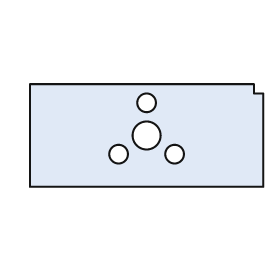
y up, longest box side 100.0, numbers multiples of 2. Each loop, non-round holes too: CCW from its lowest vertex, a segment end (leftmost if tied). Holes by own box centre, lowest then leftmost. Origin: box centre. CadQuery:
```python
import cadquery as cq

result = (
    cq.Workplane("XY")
    .moveTo(-50.0, -22.0)
    .lineTo(50.0, -22.0)
    .lineTo(50.0, 18.0)
    .lineTo(46.0, 18.0)
    .lineTo(46.0, 22.0)
    .lineTo(-50.0, 22.0)
    .close()
    .moveTo(-12.0, -8.0)
    .circle(4.0)
    .moveTo(12.0, -8.0)
    .circle(4.0)
    .moveTo(0.0, 0.0)
    .circle(6.0)
    .moveTo(0.0, 14.0)
    .circle(4.0)
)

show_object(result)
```